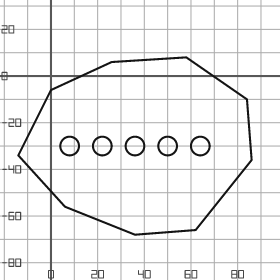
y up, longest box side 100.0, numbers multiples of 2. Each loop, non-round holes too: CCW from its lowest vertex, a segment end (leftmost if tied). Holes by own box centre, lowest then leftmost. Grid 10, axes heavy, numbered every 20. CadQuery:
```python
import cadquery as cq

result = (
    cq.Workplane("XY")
    .moveTo(36.0, -68.0)
    .lineTo(62.0, -66.0)
    .lineTo(86.0, -36.0)
    .lineTo(84.0, -10.0)
    .lineTo(58.0, 8.0)
    .lineTo(26.0, 6.0)
    .lineTo(0.0, -6.0)
    .lineTo(-14.0, -34.0)
    .lineTo(6.0, -56.0)
    .close()
    .moveTo(8.0, -30.0)
    .circle(4.0)
    .moveTo(22.0, -30.0)
    .circle(4.0)
    .moveTo(36.0, -30.0)
    .circle(4.0)
    .moveTo(50.0, -30.0)
    .circle(4.0)
    .moveTo(64.0, -30.0)
    .circle(4.0)
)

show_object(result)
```